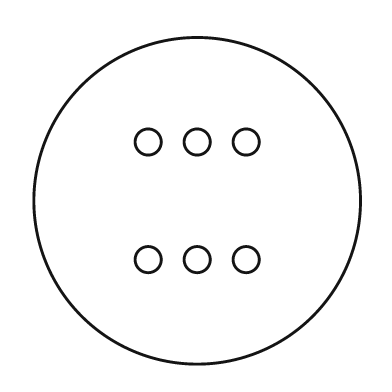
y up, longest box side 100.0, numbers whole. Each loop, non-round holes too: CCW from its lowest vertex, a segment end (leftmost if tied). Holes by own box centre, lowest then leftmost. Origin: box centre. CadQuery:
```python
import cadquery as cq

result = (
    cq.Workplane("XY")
    .moveTo(0.0, 0.0)
    .circle(50.0)
    .moveTo(-15.0, -18.0)
    .circle(4.0)
    .moveTo(0.0, -18.0)
    .circle(4.0)
    .moveTo(15.0, -18.0)
    .circle(4.0)
    .moveTo(-15.0, 18.0)
    .circle(4.0)
    .moveTo(0.0, 18.0)
    .circle(4.0)
    .moveTo(15.0, 18.0)
    .circle(4.0)
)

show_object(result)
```